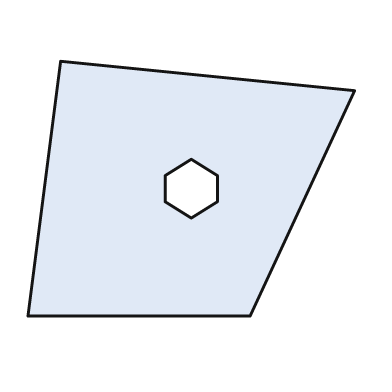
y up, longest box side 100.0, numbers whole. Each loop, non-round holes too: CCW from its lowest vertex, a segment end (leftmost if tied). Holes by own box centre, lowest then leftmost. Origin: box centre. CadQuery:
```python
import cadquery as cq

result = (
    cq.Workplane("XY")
    .moveTo(-50.0, -39.0)
    .lineTo(18.0, -39.0)
    .lineTo(50.0, 30.0)
    .lineTo(-40.0, 39.0)
    .close()
    .moveTo(0.0, -9.0)
    .lineTo(8.0, -4.0)
    .lineTo(8.0, 4.0)
    .lineTo(0.0, 9.0)
    .lineTo(-8.0, 4.0)
    .lineTo(-8.0, -4.0)
    .close()
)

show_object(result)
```